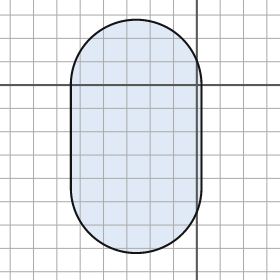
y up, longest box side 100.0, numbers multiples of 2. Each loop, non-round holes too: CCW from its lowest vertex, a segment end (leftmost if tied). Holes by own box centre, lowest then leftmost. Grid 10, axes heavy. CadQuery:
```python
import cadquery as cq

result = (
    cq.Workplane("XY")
    .moveTo(-54.0, -44.0)
    .threePointArc((-26.0, -72.0), (2.0, -44.0))
    .lineTo(2.0, 0.0)
    .threePointArc((-26.0, 28.0), (-54.0, 0.0))
    .close()
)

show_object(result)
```